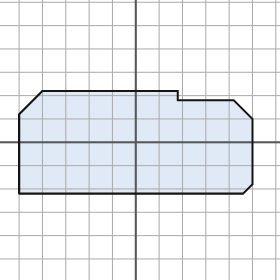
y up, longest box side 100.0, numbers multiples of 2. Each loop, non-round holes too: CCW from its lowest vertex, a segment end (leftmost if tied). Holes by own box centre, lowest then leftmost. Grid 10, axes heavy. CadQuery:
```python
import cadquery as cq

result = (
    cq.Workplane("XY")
    .moveTo(-50.0, -22.0)
    .lineTo(46.0, -22.0)
    .lineTo(50.0, -18.0)
    .lineTo(50.0, 10.0)
    .lineTo(42.0, 18.0)
    .lineTo(18.0, 18.0)
    .lineTo(18.0, 22.0)
    .lineTo(-40.0, 22.0)
    .lineTo(-50.0, 12.0)
    .close()
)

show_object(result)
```